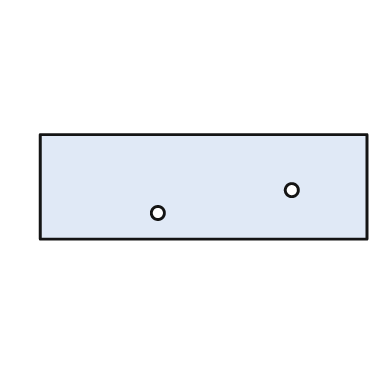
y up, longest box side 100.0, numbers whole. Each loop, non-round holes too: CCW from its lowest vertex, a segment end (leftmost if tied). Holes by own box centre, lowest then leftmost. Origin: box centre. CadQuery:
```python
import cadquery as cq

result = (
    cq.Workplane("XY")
    .moveTo(-50.0, -16.0)
    .lineTo(50.0, -16.0)
    .lineTo(50.0, 16.0)
    .lineTo(-50.0, 16.0)
    .close()
    .moveTo(-14.0, -8.0)
    .circle(2.0)
    .moveTo(27.0, -1.0)
    .circle(2.0)
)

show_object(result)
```